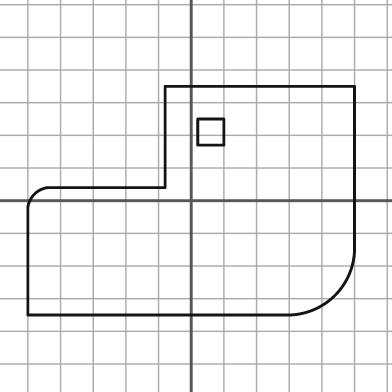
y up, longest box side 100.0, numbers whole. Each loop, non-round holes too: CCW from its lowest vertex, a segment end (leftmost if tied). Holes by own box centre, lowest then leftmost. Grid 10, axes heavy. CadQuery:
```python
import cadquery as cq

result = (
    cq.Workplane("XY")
    .moveTo(-50.0, -35.0)
    .lineTo(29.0, -35.0)
    .threePointArc((44.0, -29.0), (50.0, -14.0))
    .lineTo(50.0, 35.0)
    .lineTo(-8.0, 35.0)
    .lineTo(-8.0, 4.0)
    .lineTo(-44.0, 4.0)
    .threePointArc((-48.0, 2.0), (-50.0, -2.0))
    .close()
    .moveTo(2.0, 17.0)
    .lineTo(10.0, 17.0)
    .lineTo(10.0, 25.0)
    .lineTo(2.0, 25.0)
    .close()
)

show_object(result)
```